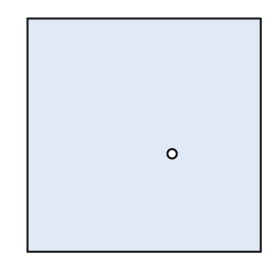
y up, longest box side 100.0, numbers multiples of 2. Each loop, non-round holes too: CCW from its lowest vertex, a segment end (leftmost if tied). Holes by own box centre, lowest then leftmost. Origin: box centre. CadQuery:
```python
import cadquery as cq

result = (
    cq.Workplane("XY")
    .moveTo(-50.0, -50.0)
    .lineTo(50.0, -50.0)
    .lineTo(50.0, 50.0)
    .lineTo(-50.0, 50.0)
    .close()
    .moveTo(12.0, -8.0)
    .circle(2.0)
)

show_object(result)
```